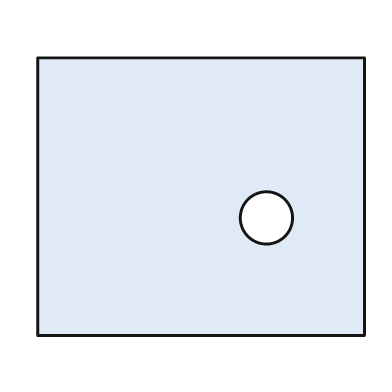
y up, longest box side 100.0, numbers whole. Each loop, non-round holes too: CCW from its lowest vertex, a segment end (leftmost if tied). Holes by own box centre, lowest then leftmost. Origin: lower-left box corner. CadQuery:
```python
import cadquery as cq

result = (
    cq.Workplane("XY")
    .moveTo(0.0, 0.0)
    .lineTo(100.0, 0.0)
    .lineTo(100.0, 85.0)
    .lineTo(0.0, 85.0)
    .close()
    .moveTo(70.0, 36.0)
    .circle(8.0)
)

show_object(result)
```